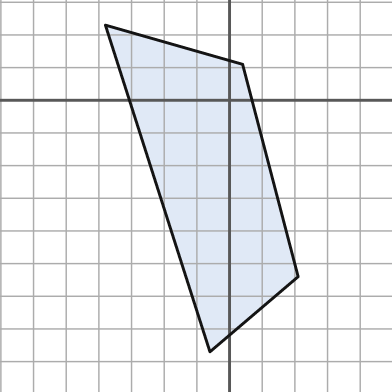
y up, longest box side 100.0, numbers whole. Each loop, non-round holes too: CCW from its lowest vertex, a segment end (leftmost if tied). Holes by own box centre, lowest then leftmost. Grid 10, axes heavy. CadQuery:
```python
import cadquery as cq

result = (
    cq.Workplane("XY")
    .moveTo(-6.0, -77.0)
    .lineTo(21.0, -54.0)
    .lineTo(4.0, 11.0)
    .lineTo(-38.0, 23.0)
    .close()
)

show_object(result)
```